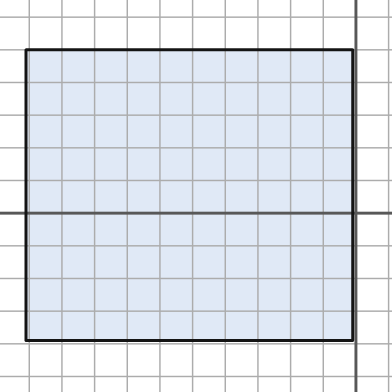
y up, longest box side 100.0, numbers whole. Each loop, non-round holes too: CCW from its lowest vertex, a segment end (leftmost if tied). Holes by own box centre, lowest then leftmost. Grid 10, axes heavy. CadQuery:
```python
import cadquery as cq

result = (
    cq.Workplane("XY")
    .moveTo(-101.0, -39.0)
    .lineTo(-1.0, -39.0)
    .lineTo(-1.0, 50.0)
    .lineTo(-101.0, 50.0)
    .close()
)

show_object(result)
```